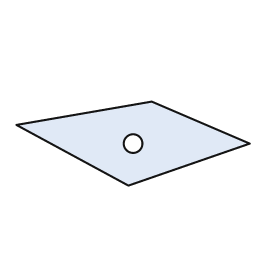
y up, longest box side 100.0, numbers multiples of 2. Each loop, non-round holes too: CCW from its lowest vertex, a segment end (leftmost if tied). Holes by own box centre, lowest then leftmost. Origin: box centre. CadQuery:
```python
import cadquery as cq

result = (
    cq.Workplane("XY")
    .moveTo(-2.0, -18.0)
    .lineTo(50.0, 0.0)
    .lineTo(8.0, 18.0)
    .lineTo(-50.0, 8.0)
    .close()
    .moveTo(0.0, 0.0)
    .circle(4.0)
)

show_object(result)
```